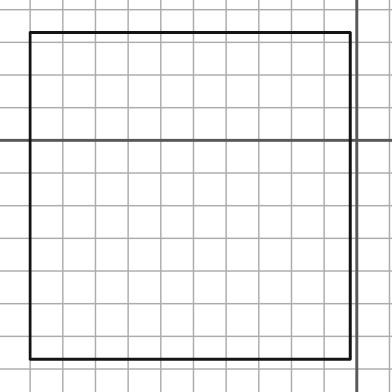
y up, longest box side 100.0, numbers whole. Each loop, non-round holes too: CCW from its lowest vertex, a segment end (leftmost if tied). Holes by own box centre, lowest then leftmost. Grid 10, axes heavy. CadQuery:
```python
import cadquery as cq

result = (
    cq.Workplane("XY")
    .moveTo(-100.0, -67.0)
    .lineTo(-2.0, -67.0)
    .lineTo(-2.0, 33.0)
    .lineTo(-100.0, 33.0)
    .close()
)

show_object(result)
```